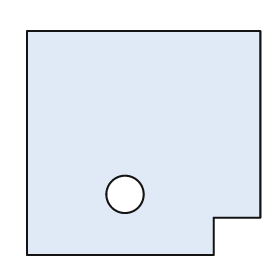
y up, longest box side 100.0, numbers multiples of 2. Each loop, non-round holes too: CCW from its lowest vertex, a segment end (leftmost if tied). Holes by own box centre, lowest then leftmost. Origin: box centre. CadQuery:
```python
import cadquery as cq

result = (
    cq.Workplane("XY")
    .moveTo(-50.0, -48.0)
    .lineTo(30.0, -48.0)
    .lineTo(30.0, -32.0)
    .lineTo(50.0, -32.0)
    .lineTo(50.0, 48.0)
    .lineTo(-50.0, 48.0)
    .close()
    .moveTo(-8.0, -22.0)
    .circle(8.0)
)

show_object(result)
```